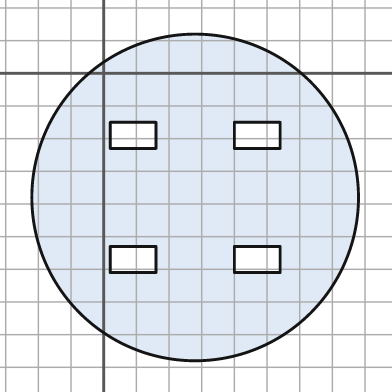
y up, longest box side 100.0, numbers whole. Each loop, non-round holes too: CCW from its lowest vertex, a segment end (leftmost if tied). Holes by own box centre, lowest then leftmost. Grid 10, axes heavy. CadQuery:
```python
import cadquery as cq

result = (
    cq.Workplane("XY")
    .moveTo(28.0, -38.0)
    .circle(50.0)
    .moveTo(2.0, -61.0)
    .lineTo(16.0, -61.0)
    .lineTo(16.0, -53.0)
    .lineTo(2.0, -53.0)
    .close()
    .moveTo(40.0, -61.0)
    .lineTo(54.0, -61.0)
    .lineTo(54.0, -53.0)
    .lineTo(40.0, -53.0)
    .close()
    .moveTo(2.0, -23.0)
    .lineTo(16.0, -23.0)
    .lineTo(16.0, -15.0)
    .lineTo(2.0, -15.0)
    .close()
    .moveTo(40.0, -23.0)
    .lineTo(54.0, -23.0)
    .lineTo(54.0, -15.0)
    .lineTo(40.0, -15.0)
    .close()
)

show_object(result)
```